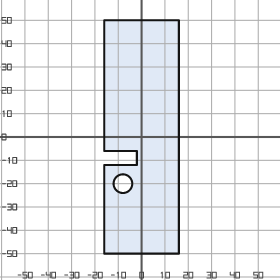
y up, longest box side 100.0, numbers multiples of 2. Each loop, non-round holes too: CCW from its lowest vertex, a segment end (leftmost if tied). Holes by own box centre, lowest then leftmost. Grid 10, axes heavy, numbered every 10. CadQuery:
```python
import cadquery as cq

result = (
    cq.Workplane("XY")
    .moveTo(-16.0, -50.0)
    .lineTo(16.0, -50.0)
    .lineTo(16.0, 50.0)
    .lineTo(-16.0, 50.0)
    .lineTo(-16.0, -6.0)
    .lineTo(-2.0, -6.0)
    .lineTo(-2.0, -12.0)
    .lineTo(-16.0, -12.0)
    .close()
    .moveTo(-8.0, -20.0)
    .circle(4.0)
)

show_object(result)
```